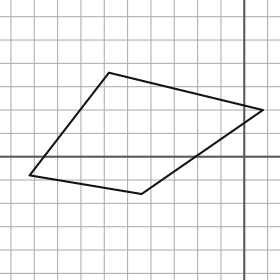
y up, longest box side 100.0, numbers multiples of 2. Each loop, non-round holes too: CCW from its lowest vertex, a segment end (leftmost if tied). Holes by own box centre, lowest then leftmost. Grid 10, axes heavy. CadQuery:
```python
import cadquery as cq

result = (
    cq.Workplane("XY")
    .moveTo(-44.0, -16.0)
    .lineTo(8.0, 20.0)
    .lineTo(-58.0, 36.0)
    .lineTo(-92.0, -8.0)
    .close()
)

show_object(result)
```